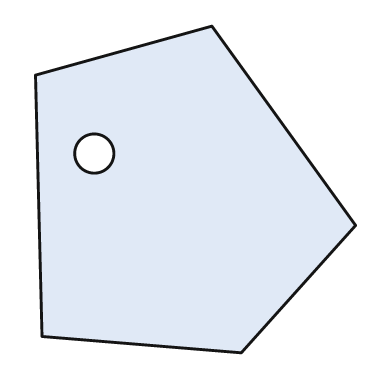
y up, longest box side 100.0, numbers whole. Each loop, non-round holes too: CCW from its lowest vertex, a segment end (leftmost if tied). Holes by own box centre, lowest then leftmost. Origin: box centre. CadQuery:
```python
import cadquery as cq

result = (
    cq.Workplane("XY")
    .moveTo(14.0, -50.0)
    .lineTo(49.0, -11.0)
    .lineTo(5.0, 50.0)
    .lineTo(-49.0, 35.0)
    .lineTo(-47.0, -45.0)
    .close()
    .moveTo(-31.0, 11.0)
    .circle(6.0)
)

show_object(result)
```